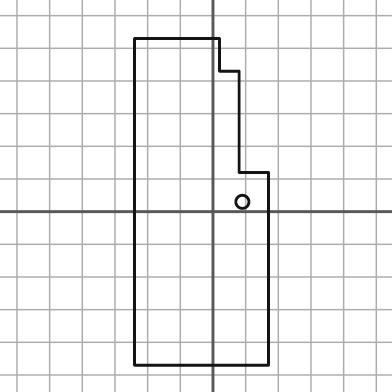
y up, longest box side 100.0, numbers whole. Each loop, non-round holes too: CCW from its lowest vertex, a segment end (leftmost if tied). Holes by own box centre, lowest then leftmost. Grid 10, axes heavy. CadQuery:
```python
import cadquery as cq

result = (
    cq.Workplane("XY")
    .moveTo(-24.0, -47.0)
    .lineTo(17.0, -47.0)
    .lineTo(17.0, 12.0)
    .lineTo(8.0, 12.0)
    .lineTo(8.0, 43.0)
    .lineTo(2.0, 43.0)
    .lineTo(2.0, 53.0)
    .lineTo(-24.0, 53.0)
    .close()
    .moveTo(9.0, 3.0)
    .circle(2.0)
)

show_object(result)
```